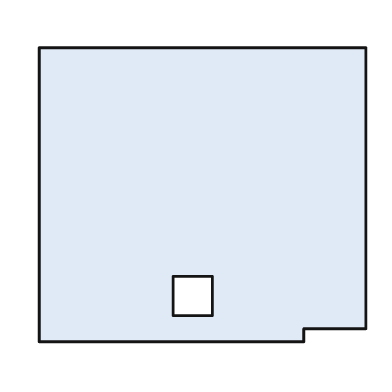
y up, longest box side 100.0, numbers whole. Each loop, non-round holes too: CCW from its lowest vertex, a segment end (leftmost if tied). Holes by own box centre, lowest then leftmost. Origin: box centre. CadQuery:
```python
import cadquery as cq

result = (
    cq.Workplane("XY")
    .moveTo(-50.0, -45.0)
    .lineTo(31.0, -45.0)
    .lineTo(31.0, -41.0)
    .lineTo(50.0, -41.0)
    .lineTo(50.0, 45.0)
    .lineTo(-50.0, 45.0)
    .close()
    .moveTo(-9.0, -37.0)
    .lineTo(3.0, -37.0)
    .lineTo(3.0, -25.0)
    .lineTo(-9.0, -25.0)
    .close()
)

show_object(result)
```